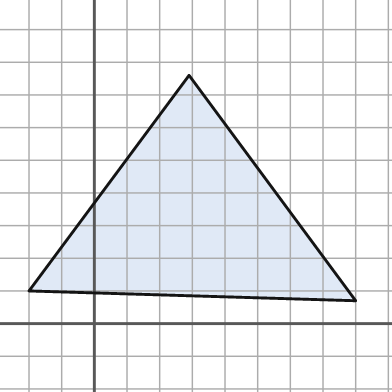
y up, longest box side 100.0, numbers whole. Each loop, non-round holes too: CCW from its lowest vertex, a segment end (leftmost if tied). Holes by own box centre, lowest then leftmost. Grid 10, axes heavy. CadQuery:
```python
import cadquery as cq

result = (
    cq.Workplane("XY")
    .moveTo(80.0, 7.0)
    .lineTo(29.0, 76.0)
    .lineTo(-20.0, 10.0)
    .close()
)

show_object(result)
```